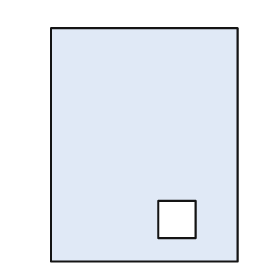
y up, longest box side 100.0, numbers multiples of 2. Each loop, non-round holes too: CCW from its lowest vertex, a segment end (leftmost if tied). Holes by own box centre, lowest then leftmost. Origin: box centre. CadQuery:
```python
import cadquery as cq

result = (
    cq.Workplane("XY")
    .moveTo(-40.0, -50.0)
    .lineTo(40.0, -50.0)
    .lineTo(40.0, 50.0)
    .lineTo(-40.0, 50.0)
    .close()
    .moveTo(6.0, -40.0)
    .lineTo(22.0, -40.0)
    .lineTo(22.0, -24.0)
    .lineTo(6.0, -24.0)
    .close()
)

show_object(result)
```